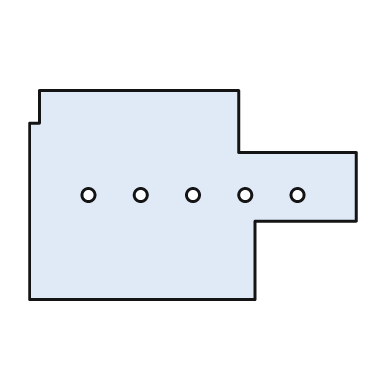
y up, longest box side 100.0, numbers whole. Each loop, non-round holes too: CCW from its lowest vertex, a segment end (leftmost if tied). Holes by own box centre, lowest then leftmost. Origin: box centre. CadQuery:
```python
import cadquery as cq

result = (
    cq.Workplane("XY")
    .moveTo(-50.0, -32.0)
    .lineTo(19.0, -32.0)
    .lineTo(19.0, -8.0)
    .lineTo(50.0, -8.0)
    .lineTo(50.0, 13.0)
    .lineTo(14.0, 13.0)
    .lineTo(14.0, 32.0)
    .lineTo(-47.0, 32.0)
    .lineTo(-47.0, 22.0)
    .lineTo(-50.0, 22.0)
    .close()
    .moveTo(-32.0, 0.0)
    .circle(2.0)
    .moveTo(-16.0, 0.0)
    .circle(2.0)
    .moveTo(0.0, 0.0)
    .circle(2.0)
    .moveTo(16.0, 0.0)
    .circle(2.0)
    .moveTo(32.0, 0.0)
    .circle(2.0)
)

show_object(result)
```